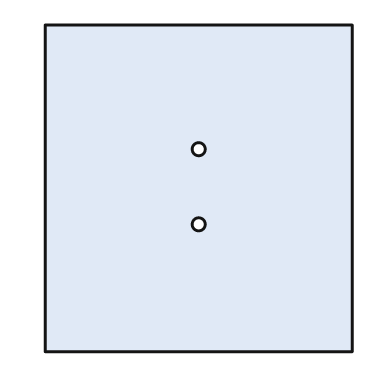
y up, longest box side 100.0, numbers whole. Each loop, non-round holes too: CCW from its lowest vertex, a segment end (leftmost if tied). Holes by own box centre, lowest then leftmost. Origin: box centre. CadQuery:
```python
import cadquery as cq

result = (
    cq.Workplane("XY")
    .moveTo(-47.0, -50.0)
    .lineTo(47.0, -50.0)
    .lineTo(47.0, 50.0)
    .lineTo(-47.0, 50.0)
    .close()
    .moveTo(0.0, -11.0)
    .circle(2.0)
    .moveTo(0.0, 12.0)
    .circle(2.0)
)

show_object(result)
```